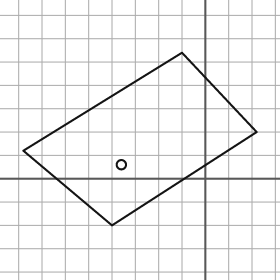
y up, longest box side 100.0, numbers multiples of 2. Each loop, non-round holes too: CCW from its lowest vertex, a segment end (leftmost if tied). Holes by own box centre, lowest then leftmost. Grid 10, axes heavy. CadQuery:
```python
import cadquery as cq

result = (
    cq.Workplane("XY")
    .moveTo(-40.0, -20.0)
    .lineTo(22.0, 20.0)
    .lineTo(-10.0, 54.0)
    .lineTo(-78.0, 12.0)
    .close()
    .moveTo(-36.0, 6.0)
    .circle(2.0)
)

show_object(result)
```